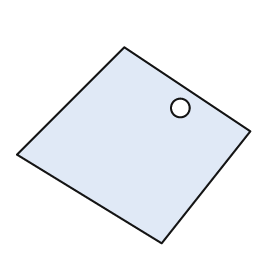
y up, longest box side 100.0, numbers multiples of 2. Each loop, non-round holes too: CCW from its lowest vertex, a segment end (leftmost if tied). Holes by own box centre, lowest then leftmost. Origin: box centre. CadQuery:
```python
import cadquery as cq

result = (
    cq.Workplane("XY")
    .moveTo(12.0, -42.0)
    .lineTo(50.0, 6.0)
    .lineTo(-4.0, 42.0)
    .lineTo(-50.0, -4.0)
    .close()
    .moveTo(20.0, 16.0)
    .circle(4.0)
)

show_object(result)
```